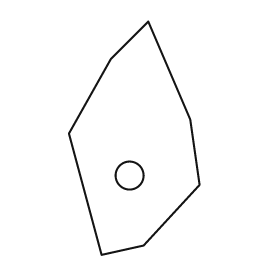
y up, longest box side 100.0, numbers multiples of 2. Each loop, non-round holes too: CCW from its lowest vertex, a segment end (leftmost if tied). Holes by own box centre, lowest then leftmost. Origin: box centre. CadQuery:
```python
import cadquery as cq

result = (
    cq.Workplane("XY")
    .moveTo(-14.0, -50.0)
    .lineTo(4.0, -46.0)
    .lineTo(28.0, -20.0)
    .lineTo(24.0, 8.0)
    .lineTo(6.0, 50.0)
    .lineTo(-10.0, 34.0)
    .lineTo(-28.0, 2.0)
    .close()
    .moveTo(-2.0, -16.0)
    .circle(6.0)
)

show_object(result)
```